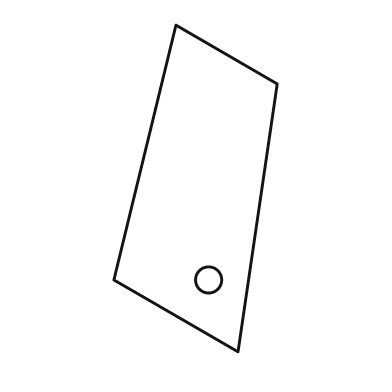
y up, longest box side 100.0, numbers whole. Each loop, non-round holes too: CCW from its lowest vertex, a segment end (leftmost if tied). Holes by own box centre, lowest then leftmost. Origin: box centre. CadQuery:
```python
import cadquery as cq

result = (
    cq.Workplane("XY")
    .moveTo(13.0, -50.0)
    .lineTo(25.0, 32.0)
    .lineTo(-6.0, 50.0)
    .lineTo(-25.0, -28.0)
    .close()
    .moveTo(4.0, -28.0)
    .circle(4.0)
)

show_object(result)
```